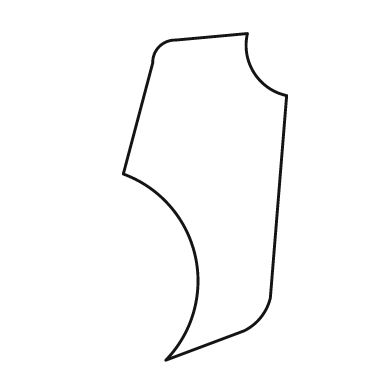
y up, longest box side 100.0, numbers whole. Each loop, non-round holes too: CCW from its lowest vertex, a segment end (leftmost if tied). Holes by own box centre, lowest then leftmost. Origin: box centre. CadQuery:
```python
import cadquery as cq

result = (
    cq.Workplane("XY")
    .moveTo(-12.0, -50.0)
    .lineTo(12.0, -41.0)
    .threePointArc((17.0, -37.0), (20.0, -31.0))
    .lineTo(25.0, 31.0)
    .threePointArc((15.0, 38.0), (13.0, 50.0))
    .lineTo(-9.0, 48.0)
    .threePointArc((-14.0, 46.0), (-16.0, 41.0))
    .lineTo(-25.0, 7.0)
    .threePointArc((-3.0, -18.0), (-12.0, -50.0))
    .close()
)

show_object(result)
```